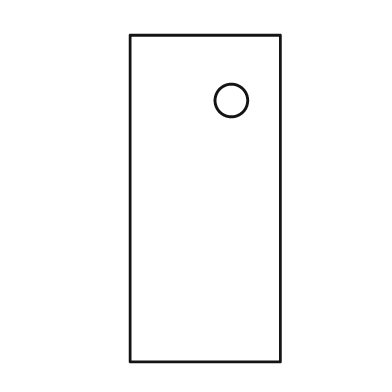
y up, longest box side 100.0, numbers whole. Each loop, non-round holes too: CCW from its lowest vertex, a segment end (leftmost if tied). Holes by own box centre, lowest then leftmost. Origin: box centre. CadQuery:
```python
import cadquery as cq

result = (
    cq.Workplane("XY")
    .moveTo(-23.0, -50.0)
    .lineTo(23.0, -50.0)
    .lineTo(23.0, 50.0)
    .lineTo(-23.0, 50.0)
    .close()
    .moveTo(8.0, 30.0)
    .circle(5.0)
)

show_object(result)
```